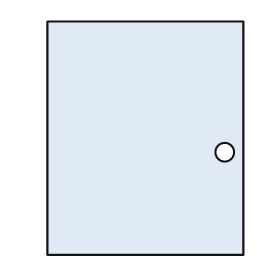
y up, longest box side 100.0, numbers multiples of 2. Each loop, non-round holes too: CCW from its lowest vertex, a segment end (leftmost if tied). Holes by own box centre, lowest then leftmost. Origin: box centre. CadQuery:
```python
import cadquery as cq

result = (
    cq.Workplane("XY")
    .moveTo(-42.0, -50.0)
    .lineTo(42.0, -50.0)
    .lineTo(42.0, 50.0)
    .lineTo(-42.0, 50.0)
    .close()
    .moveTo(34.0, -6.0)
    .circle(4.0)
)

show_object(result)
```